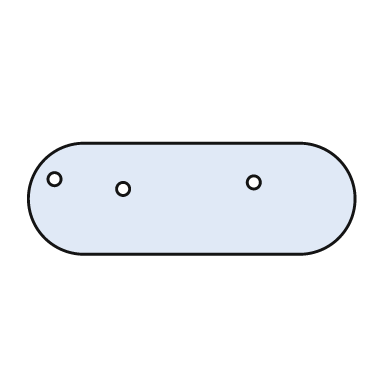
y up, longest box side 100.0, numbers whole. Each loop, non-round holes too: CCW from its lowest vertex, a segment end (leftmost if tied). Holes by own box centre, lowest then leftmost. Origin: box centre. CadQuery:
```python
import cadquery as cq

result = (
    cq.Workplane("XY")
    .moveTo(-33.0, -17.0)
    .lineTo(33.0, -17.0)
    .threePointArc((50.0, 0.0), (33.0, 17.0))
    .lineTo(-33.0, 17.0)
    .threePointArc((-50.0, 0.0), (-33.0, -17.0))
    .close()
    .moveTo(-21.0, 3.0)
    .circle(2.0)
    .moveTo(19.0, 5.0)
    .circle(2.0)
    .moveTo(-42.0, 6.0)
    .circle(2.0)
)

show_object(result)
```